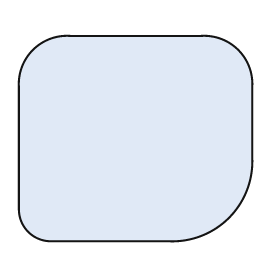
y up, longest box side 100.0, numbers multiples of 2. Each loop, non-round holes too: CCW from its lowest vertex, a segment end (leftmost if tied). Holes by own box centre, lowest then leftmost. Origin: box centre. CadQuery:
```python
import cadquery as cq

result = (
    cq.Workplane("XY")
    .moveTo(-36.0, -44.0)
    .lineTo(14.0, -44.0)
    .threePointArc((40.0, -34.0), (50.0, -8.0))
    .lineTo(50.0, 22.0)
    .threePointArc((44.0, 38.0), (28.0, 44.0))
    .lineTo(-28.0, 44.0)
    .threePointArc((-44.0, 38.0), (-50.0, 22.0))
    .lineTo(-50.0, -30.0)
    .threePointArc((-46.0, -40.0), (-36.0, -44.0))
    .close()
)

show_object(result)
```